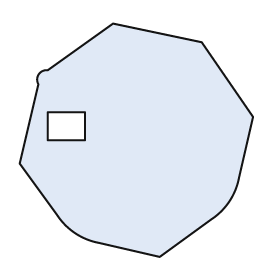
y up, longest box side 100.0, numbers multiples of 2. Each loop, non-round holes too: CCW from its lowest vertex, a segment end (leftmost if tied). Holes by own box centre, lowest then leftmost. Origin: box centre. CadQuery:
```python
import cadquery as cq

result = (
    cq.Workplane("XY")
    .moveTo(10.0, -50.0)
    .lineTo(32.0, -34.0)
    .threePointArc((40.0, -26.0), (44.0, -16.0))
    .lineTo(50.0, 10.0)
    .lineTo(28.0, 42.0)
    .lineTo(-10.0, 50.0)
    .lineTo(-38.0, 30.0)
    .threePointArc((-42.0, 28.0), (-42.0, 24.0))
    .lineTo(-50.0, -10.0)
    .lineTo(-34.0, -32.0)
    .threePointArc((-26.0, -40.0), (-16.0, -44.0))
    .close()
    .moveTo(-38.0, 0.0)
    .lineTo(-22.0, 0.0)
    .lineTo(-22.0, 12.0)
    .lineTo(-38.0, 12.0)
    .close()
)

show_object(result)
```